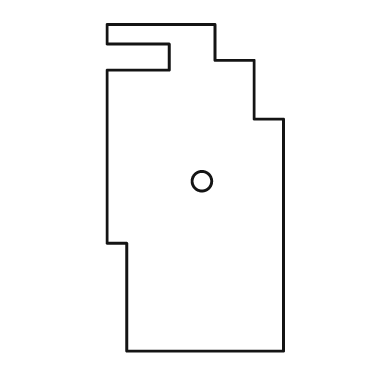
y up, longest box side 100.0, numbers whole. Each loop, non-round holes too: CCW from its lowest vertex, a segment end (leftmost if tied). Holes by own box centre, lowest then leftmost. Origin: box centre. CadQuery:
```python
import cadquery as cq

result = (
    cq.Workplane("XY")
    .moveTo(-21.0, -50.0)
    .lineTo(27.0, -50.0)
    .lineTo(27.0, 21.0)
    .lineTo(18.0, 21.0)
    .lineTo(18.0, 39.0)
    .lineTo(6.0, 39.0)
    .lineTo(6.0, 50.0)
    .lineTo(-27.0, 50.0)
    .lineTo(-27.0, 44.0)
    .lineTo(-8.0, 44.0)
    .lineTo(-8.0, 36.0)
    .lineTo(-27.0, 36.0)
    .lineTo(-27.0, -17.0)
    .lineTo(-21.0, -17.0)
    .close()
    .moveTo(2.0, 2.0)
    .circle(3.0)
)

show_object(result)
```